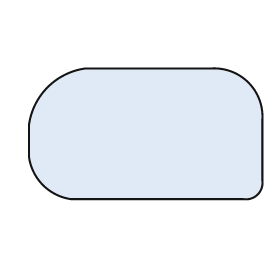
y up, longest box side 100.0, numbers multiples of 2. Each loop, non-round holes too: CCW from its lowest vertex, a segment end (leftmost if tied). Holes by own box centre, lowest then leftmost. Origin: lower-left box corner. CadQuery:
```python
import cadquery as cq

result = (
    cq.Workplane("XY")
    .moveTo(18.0, 0.0)
    .lineTo(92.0, 0.0)
    .threePointArc((98.0, 2.0), (100.0, 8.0))
    .lineTo(100.0, 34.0)
    .threePointArc((94.0, 50.0), (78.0, 56.0))
    .lineTo(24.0, 56.0)
    .threePointArc((8.0, 48.0), (0.0, 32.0))
    .lineTo(0.0, 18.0)
    .threePointArc((6.0, 6.0), (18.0, 0.0))
    .close()
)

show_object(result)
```